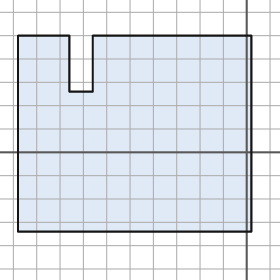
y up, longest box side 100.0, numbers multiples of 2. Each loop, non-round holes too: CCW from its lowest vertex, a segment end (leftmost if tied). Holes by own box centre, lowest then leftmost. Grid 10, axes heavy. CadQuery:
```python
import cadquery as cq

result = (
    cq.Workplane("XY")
    .moveTo(-98.0, -34.0)
    .lineTo(2.0, -34.0)
    .lineTo(2.0, 50.0)
    .lineTo(-66.0, 50.0)
    .lineTo(-66.0, 26.0)
    .lineTo(-76.0, 26.0)
    .lineTo(-76.0, 50.0)
    .lineTo(-98.0, 50.0)
    .close()
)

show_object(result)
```